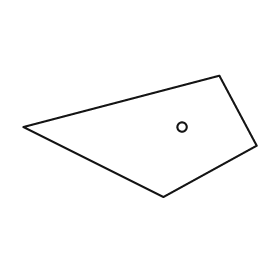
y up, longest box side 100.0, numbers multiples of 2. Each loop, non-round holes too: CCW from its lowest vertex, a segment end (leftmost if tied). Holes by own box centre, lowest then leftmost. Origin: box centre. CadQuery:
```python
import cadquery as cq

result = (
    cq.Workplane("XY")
    .moveTo(10.0, -26.0)
    .lineTo(50.0, -4.0)
    .lineTo(34.0, 26.0)
    .lineTo(-50.0, 4.0)
    .close()
    .moveTo(18.0, 4.0)
    .circle(2.0)
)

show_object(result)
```